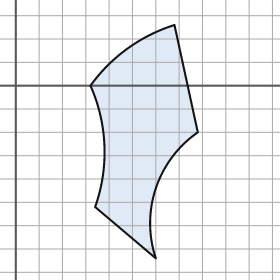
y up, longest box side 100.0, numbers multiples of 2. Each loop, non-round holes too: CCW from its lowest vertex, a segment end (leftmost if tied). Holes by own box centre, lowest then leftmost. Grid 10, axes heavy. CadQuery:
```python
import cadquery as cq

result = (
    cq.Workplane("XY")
    .moveTo(60.0, -74.0)
    .threePointArc((60.0, -44.0), (78.0, -20.0))
    .lineTo(68.0, 26.0)
    .threePointArc((48.0, 16.0), (32.0, 0.0))
    .threePointArc((38.0, -26.0), (34.0, -52.0))
    .close()
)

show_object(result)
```